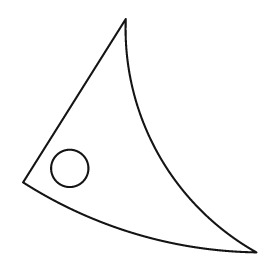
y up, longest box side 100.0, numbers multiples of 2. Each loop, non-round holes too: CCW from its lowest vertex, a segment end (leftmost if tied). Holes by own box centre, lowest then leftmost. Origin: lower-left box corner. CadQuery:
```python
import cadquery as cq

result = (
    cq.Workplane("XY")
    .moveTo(100.0, 0.0)
    .threePointArc((58.0, 42.0), (44.0, 100.0))
    .lineTo(0.0, 30.0)
    .threePointArc((48.0, 8.0), (100.0, 0.0))
    .close()
    .moveTo(20.0, 36.0)
    .circle(8.0)
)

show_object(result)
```